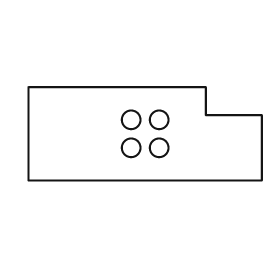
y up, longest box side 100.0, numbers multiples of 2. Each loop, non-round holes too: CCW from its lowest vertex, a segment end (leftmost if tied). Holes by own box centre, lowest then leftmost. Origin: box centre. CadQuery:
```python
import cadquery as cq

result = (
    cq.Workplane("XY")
    .moveTo(-50.0, -20.0)
    .lineTo(50.0, -20.0)
    .lineTo(50.0, 8.0)
    .lineTo(26.0, 8.0)
    .lineTo(26.0, 20.0)
    .lineTo(-50.0, 20.0)
    .close()
    .moveTo(-6.0, -6.0)
    .circle(4.0)
    .moveTo(6.0, -6.0)
    .circle(4.0)
    .moveTo(-6.0, 6.0)
    .circle(4.0)
    .moveTo(6.0, 6.0)
    .circle(4.0)
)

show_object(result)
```